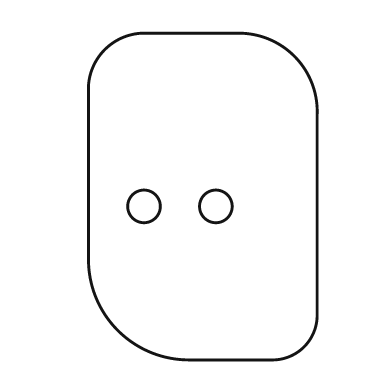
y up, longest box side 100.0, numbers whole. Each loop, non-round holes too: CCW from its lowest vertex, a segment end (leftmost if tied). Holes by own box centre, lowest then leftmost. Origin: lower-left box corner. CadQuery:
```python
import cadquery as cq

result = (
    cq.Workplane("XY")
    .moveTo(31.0, 0.0)
    .lineTo(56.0, 0.0)
    .threePointArc((66.0, 4.0), (70.0, 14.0))
    .lineTo(70.0, 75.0)
    .threePointArc((63.0, 93.0), (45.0, 100.0))
    .lineTo(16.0, 100.0)
    .threePointArc((5.0, 95.0), (0.0, 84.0))
    .lineTo(0.0, 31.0)
    .threePointArc((9.0, 9.0), (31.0, 0.0))
    .close()
    .moveTo(17.0, 47.0)
    .circle(5.0)
    .moveTo(39.0, 47.0)
    .circle(5.0)
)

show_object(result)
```